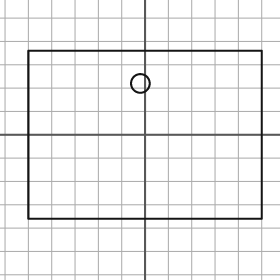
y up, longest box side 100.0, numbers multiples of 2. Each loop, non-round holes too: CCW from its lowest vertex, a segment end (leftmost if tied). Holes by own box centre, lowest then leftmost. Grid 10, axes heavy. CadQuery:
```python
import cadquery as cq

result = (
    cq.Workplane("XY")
    .moveTo(-50.0, -36.0)
    .lineTo(50.0, -36.0)
    .lineTo(50.0, 36.0)
    .lineTo(-50.0, 36.0)
    .close()
    .moveTo(-2.0, 22.0)
    .circle(4.0)
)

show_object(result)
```